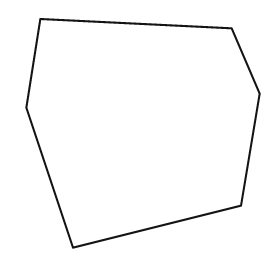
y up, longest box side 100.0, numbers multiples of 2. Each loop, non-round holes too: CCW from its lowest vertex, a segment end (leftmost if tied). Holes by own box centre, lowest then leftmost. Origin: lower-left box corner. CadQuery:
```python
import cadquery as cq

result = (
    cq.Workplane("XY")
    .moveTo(20.0, 0.0)
    .lineTo(92.0, 18.0)
    .lineTo(100.0, 66.0)
    .lineTo(88.0, 94.0)
    .lineTo(6.0, 98.0)
    .lineTo(0.0, 60.0)
    .close()
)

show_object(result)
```